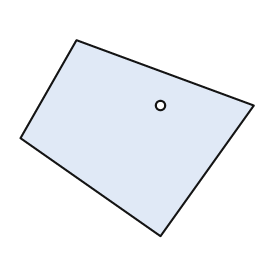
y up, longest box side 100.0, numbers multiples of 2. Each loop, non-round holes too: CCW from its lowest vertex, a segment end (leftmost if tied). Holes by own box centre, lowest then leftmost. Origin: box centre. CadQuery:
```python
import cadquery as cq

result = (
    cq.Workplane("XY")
    .moveTo(10.0, -42.0)
    .lineTo(50.0, 14.0)
    .lineTo(-26.0, 42.0)
    .lineTo(-50.0, 0.0)
    .close()
    .moveTo(10.0, 14.0)
    .circle(2.0)
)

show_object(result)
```